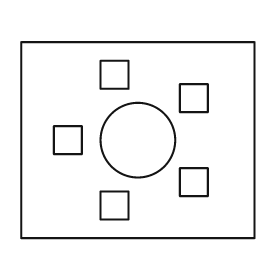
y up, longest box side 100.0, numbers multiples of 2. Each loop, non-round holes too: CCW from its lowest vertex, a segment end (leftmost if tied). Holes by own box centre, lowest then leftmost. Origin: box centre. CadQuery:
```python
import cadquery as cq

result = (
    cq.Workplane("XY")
    .moveTo(-50.0, -42.0)
    .lineTo(50.0, -42.0)
    .lineTo(50.0, 42.0)
    .lineTo(-50.0, 42.0)
    .close()
    .moveTo(-16.0, -34.0)
    .lineTo(-4.0, -34.0)
    .lineTo(-4.0, -22.0)
    .lineTo(-16.0, -22.0)
    .close()
    .moveTo(18.0, -24.0)
    .lineTo(30.0, -24.0)
    .lineTo(30.0, -12.0)
    .lineTo(18.0, -12.0)
    .close()
    .moveTo(-36.0, -6.0)
    .lineTo(-24.0, -6.0)
    .lineTo(-24.0, 6.0)
    .lineTo(-36.0, 6.0)
    .close()
    .moveTo(0.0, 0.0)
    .circle(16.0)
    .moveTo(18.0, 12.0)
    .lineTo(30.0, 12.0)
    .lineTo(30.0, 24.0)
    .lineTo(18.0, 24.0)
    .close()
    .moveTo(-16.0, 22.0)
    .lineTo(-4.0, 22.0)
    .lineTo(-4.0, 34.0)
    .lineTo(-16.0, 34.0)
    .close()
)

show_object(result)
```